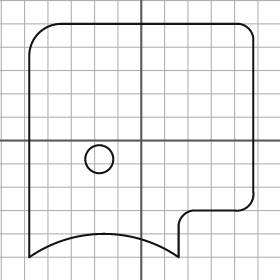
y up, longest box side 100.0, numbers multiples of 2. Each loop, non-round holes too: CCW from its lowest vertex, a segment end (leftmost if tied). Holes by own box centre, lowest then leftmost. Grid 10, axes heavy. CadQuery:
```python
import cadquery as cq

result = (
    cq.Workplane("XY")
    .moveTo(-48.0, -50.0)
    .threePointArc((-16.0, -40.0), (16.0, -50.0))
    .lineTo(16.0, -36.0)
    .threePointArc((18.0, -32.0), (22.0, -30.0))
    .lineTo(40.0, -30.0)
    .threePointArc((46.0, -28.0), (48.0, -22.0))
    .lineTo(48.0, 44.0)
    .threePointArc((46.0, 48.0), (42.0, 50.0))
    .lineTo(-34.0, 50.0)
    .threePointArc((-44.0, 46.0), (-48.0, 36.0))
    .close()
    .moveTo(-18.0, -8.0)
    .circle(6.0)
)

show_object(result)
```